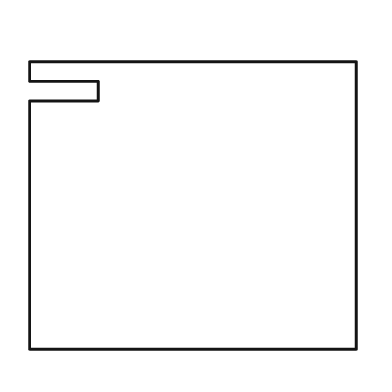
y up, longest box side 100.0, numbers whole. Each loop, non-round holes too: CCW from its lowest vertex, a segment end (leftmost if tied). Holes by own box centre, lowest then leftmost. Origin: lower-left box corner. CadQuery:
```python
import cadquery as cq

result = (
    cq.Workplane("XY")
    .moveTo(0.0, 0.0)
    .lineTo(100.0, 0.0)
    .lineTo(100.0, 88.0)
    .lineTo(0.0, 88.0)
    .lineTo(0.0, 82.0)
    .lineTo(21.0, 82.0)
    .lineTo(21.0, 76.0)
    .lineTo(0.0, 76.0)
    .close()
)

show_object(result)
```